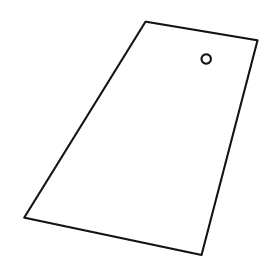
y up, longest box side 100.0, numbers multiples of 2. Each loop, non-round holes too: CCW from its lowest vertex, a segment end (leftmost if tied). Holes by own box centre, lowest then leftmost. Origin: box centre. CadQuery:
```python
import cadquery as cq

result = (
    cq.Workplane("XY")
    .moveTo(26.0, -50.0)
    .lineTo(50.0, 42.0)
    .lineTo(2.0, 50.0)
    .lineTo(-50.0, -34.0)
    .close()
    .moveTo(28.0, 34.0)
    .circle(2.0)
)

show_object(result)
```